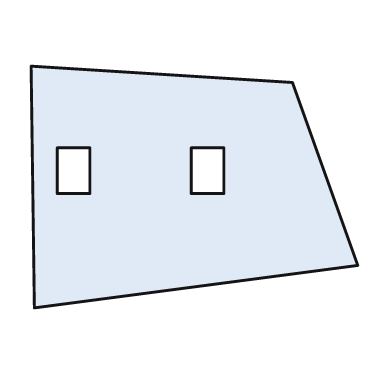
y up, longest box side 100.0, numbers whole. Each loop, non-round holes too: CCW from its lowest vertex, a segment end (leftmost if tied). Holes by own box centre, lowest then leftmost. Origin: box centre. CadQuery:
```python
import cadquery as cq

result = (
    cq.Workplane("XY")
    .moveTo(-49.0, -37.0)
    .lineTo(50.0, -24.0)
    .lineTo(30.0, 32.0)
    .lineTo(-50.0, 37.0)
    .close()
    .moveTo(-42.0, -2.0)
    .lineTo(-32.0, -2.0)
    .lineTo(-32.0, 12.0)
    .lineTo(-42.0, 12.0)
    .close()
    .moveTo(-1.0, -2.0)
    .lineTo(9.0, -2.0)
    .lineTo(9.0, 12.0)
    .lineTo(-1.0, 12.0)
    .close()
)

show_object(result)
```